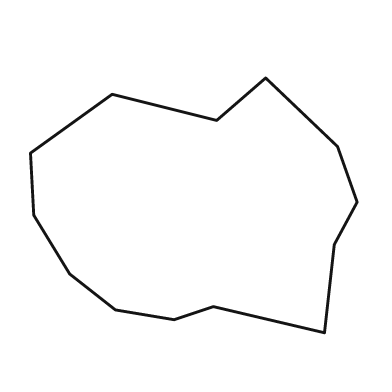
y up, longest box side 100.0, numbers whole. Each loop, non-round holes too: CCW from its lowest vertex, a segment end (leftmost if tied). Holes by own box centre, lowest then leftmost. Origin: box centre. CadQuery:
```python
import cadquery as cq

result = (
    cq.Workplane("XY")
    .moveTo(40.0, -39.0)
    .lineTo(43.0, -12.0)
    .lineTo(50.0, 1.0)
    .lineTo(44.0, 18.0)
    .lineTo(22.0, 39.0)
    .lineTo(7.0, 26.0)
    .lineTo(-25.0, 34.0)
    .lineTo(-50.0, 16.0)
    .lineTo(-49.0, -3.0)
    .lineTo(-38.0, -21.0)
    .lineTo(-24.0, -32.0)
    .lineTo(-6.0, -35.0)
    .lineTo(6.0, -31.0)
    .close()
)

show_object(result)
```